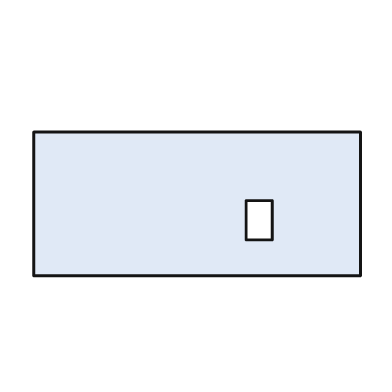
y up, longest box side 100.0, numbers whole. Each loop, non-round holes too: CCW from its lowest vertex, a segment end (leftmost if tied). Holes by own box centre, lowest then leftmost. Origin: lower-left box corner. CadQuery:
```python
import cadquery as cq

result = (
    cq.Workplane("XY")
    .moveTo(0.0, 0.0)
    .lineTo(100.0, 0.0)
    .lineTo(100.0, 44.0)
    .lineTo(0.0, 44.0)
    .close()
    .moveTo(65.0, 11.0)
    .lineTo(73.0, 11.0)
    .lineTo(73.0, 23.0)
    .lineTo(65.0, 23.0)
    .close()
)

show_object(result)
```